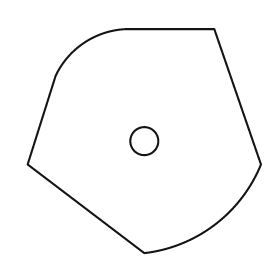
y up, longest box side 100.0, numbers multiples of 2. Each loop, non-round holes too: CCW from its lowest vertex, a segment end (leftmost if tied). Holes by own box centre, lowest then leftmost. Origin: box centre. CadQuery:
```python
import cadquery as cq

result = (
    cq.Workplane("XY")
    .moveTo(0.0, -48.0)
    .threePointArc((30.0, -36.0), (50.0, -10.0))
    .lineTo(30.0, 48.0)
    .lineTo(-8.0, 48.0)
    .threePointArc((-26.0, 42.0), (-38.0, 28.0))
    .lineTo(-50.0, -10.0)
    .close()
    .moveTo(0.0, 0.0)
    .circle(6.0)
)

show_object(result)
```